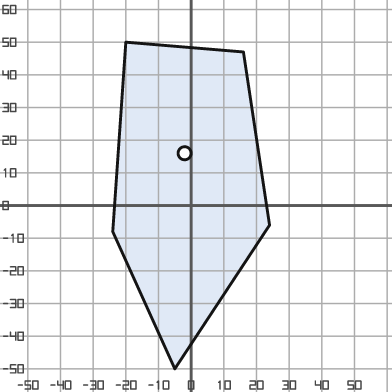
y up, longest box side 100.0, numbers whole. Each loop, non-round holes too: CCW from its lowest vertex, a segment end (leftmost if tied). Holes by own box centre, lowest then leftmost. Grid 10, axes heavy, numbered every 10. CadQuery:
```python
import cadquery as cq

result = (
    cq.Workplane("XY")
    .moveTo(-5.0, -50.0)
    .lineTo(24.0, -6.0)
    .lineTo(16.0, 47.0)
    .lineTo(-20.0, 50.0)
    .lineTo(-24.0, -8.0)
    .close()
    .moveTo(-2.0, 16.0)
    .circle(2.0)
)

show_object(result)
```